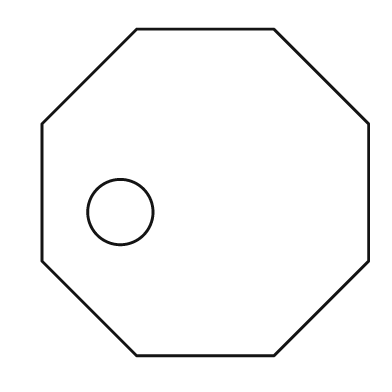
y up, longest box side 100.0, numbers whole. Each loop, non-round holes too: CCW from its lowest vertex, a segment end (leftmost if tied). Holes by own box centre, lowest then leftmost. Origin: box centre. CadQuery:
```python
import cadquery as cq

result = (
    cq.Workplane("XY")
    .moveTo(-21.0, -50.0)
    .lineTo(21.0, -50.0)
    .lineTo(50.0, -21.0)
    .lineTo(50.0, 21.0)
    .lineTo(21.0, 50.0)
    .lineTo(-21.0, 50.0)
    .lineTo(-50.0, 21.0)
    .lineTo(-50.0, -21.0)
    .close()
    .moveTo(-26.0, -6.0)
    .circle(10.0)
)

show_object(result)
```